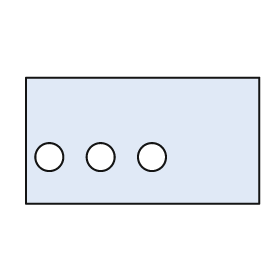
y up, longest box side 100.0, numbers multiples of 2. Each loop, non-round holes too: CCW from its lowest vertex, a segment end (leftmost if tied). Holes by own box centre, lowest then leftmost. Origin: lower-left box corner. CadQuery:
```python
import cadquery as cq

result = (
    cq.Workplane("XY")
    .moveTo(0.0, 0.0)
    .lineTo(100.0, 0.0)
    .lineTo(100.0, 54.0)
    .lineTo(0.0, 54.0)
    .close()
    .moveTo(10.0, 20.0)
    .circle(6.0)
    .moveTo(32.0, 20.0)
    .circle(6.0)
    .moveTo(54.0, 20.0)
    .circle(6.0)
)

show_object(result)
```